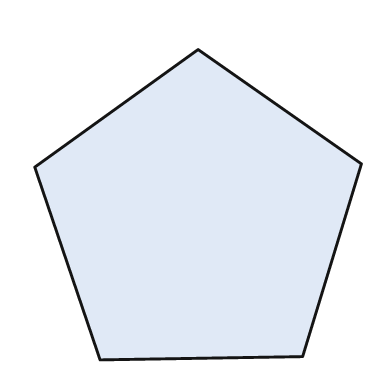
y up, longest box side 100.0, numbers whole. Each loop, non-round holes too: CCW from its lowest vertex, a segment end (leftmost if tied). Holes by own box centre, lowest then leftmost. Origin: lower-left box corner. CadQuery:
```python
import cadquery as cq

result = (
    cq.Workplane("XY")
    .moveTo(20.0, 0.0)
    .lineTo(82.0, 1.0)
    .lineTo(100.0, 60.0)
    .lineTo(50.0, 95.0)
    .lineTo(0.0, 59.0)
    .close()
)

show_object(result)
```